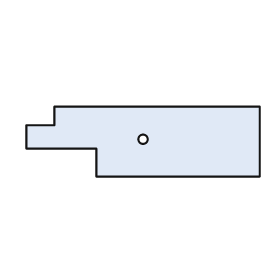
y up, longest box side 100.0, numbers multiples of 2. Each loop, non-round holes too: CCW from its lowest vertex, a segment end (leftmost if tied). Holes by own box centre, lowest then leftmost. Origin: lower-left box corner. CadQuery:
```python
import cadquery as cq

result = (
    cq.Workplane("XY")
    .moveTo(30.0, 0.0)
    .lineTo(100.0, 0.0)
    .lineTo(100.0, 30.0)
    .lineTo(12.0, 30.0)
    .lineTo(12.0, 22.0)
    .lineTo(0.0, 22.0)
    .lineTo(0.0, 12.0)
    .lineTo(30.0, 12.0)
    .close()
    .moveTo(50.0, 16.0)
    .circle(2.0)
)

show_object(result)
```